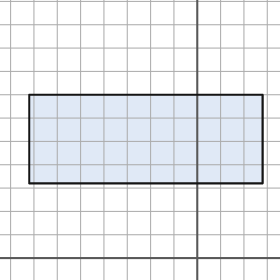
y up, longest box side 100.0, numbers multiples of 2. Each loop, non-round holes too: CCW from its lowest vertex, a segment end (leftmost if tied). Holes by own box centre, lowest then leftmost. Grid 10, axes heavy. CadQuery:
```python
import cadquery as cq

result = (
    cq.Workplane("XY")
    .moveTo(-72.0, 32.0)
    .lineTo(28.0, 32.0)
    .lineTo(28.0, 70.0)
    .lineTo(-72.0, 70.0)
    .close()
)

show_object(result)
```